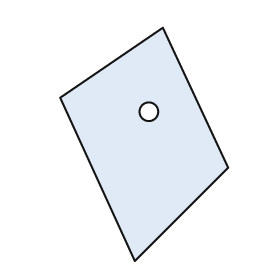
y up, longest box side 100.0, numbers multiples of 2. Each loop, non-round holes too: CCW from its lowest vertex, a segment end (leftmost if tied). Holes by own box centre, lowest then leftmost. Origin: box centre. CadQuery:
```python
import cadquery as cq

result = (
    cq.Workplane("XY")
    .moveTo(-4.0, -50.0)
    .lineTo(36.0, -10.0)
    .lineTo(8.0, 50.0)
    .lineTo(-36.0, 20.0)
    .close()
    .moveTo(2.0, 14.0)
    .circle(4.0)
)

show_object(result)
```